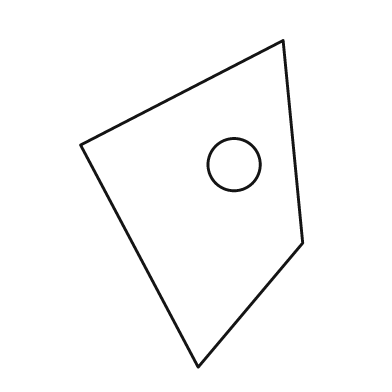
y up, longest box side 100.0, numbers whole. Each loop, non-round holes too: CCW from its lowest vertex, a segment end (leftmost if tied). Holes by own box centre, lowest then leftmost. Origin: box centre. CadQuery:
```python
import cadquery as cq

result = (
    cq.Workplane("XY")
    .moveTo(2.0, -50.0)
    .lineTo(34.0, -12.0)
    .lineTo(28.0, 50.0)
    .lineTo(-34.0, 18.0)
    .close()
    .moveTo(13.0, 12.0)
    .circle(8.0)
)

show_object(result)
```